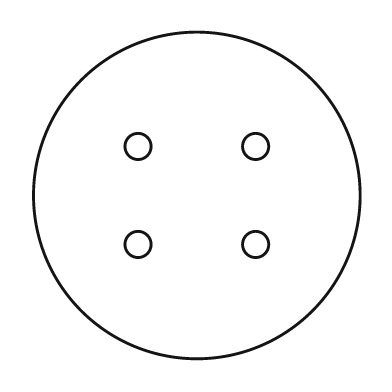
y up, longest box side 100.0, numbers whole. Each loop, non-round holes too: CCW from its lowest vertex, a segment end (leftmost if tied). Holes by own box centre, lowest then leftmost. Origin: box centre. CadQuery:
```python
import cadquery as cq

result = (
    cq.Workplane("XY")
    .moveTo(0.0, 0.0)
    .circle(50.0)
    .moveTo(-18.0, -15.0)
    .circle(4.0)
    .moveTo(18.0, -15.0)
    .circle(4.0)
    .moveTo(-18.0, 15.0)
    .circle(4.0)
    .moveTo(18.0, 15.0)
    .circle(4.0)
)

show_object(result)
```